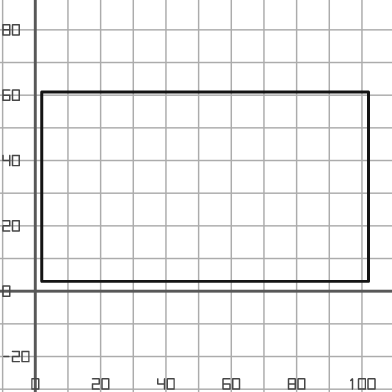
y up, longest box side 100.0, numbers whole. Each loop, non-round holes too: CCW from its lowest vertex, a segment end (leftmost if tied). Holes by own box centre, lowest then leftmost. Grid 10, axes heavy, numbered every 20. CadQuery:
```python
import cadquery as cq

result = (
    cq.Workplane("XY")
    .moveTo(2.0, 3.0)
    .lineTo(102.0, 3.0)
    .lineTo(102.0, 61.0)
    .lineTo(2.0, 61.0)
    .close()
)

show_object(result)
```